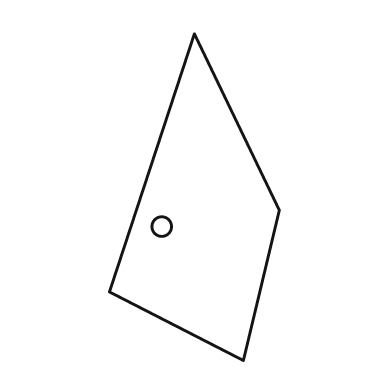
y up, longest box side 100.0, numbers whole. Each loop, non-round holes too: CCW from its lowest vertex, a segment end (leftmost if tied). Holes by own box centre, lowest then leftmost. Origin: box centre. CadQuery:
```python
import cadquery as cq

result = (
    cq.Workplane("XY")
    .moveTo(15.0, -50.0)
    .lineTo(26.0, -4.0)
    .lineTo(0.0, 50.0)
    .lineTo(-26.0, -29.0)
    .close()
    .moveTo(-10.0, -9.0)
    .circle(3.0)
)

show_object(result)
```